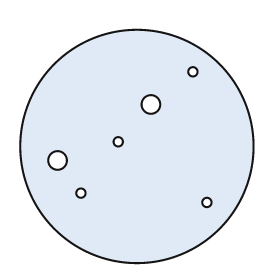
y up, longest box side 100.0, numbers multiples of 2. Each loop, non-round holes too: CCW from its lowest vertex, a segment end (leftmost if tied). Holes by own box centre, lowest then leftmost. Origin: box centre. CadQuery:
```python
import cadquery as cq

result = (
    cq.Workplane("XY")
    .moveTo(0.0, 0.0)
    .circle(50.0)
    .moveTo(30.0, -24.0)
    .circle(2.0)
    .moveTo(-24.0, -20.0)
    .circle(2.0)
    .moveTo(-34.0, -6.0)
    .circle(4.0)
    .moveTo(-8.0, 2.0)
    .circle(2.0)
    .moveTo(6.0, 18.0)
    .circle(4.0)
    .moveTo(24.0, 32.0)
    .circle(2.0)
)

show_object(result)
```